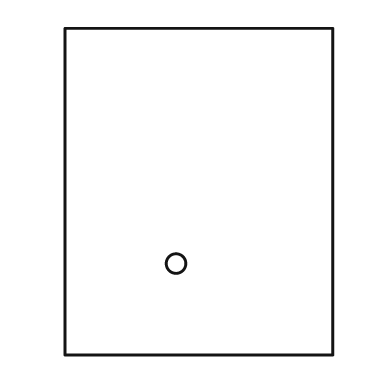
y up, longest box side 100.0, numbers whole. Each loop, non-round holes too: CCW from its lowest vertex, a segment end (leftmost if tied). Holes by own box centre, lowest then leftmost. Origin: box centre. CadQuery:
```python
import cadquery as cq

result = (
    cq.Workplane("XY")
    .moveTo(-41.0, -50.0)
    .lineTo(41.0, -50.0)
    .lineTo(41.0, 50.0)
    .lineTo(-41.0, 50.0)
    .close()
    .moveTo(-7.0, -22.0)
    .circle(3.0)
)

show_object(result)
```